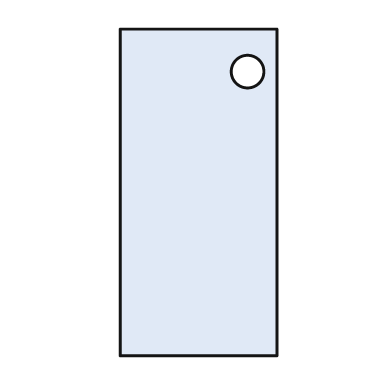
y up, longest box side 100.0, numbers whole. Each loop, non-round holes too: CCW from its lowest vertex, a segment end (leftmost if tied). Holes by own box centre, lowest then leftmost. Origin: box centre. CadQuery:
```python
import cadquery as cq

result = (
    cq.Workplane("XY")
    .moveTo(-24.0, -50.0)
    .lineTo(24.0, -50.0)
    .lineTo(24.0, 50.0)
    .lineTo(-24.0, 50.0)
    .close()
    .moveTo(15.0, 37.0)
    .circle(5.0)
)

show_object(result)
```